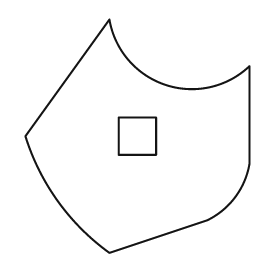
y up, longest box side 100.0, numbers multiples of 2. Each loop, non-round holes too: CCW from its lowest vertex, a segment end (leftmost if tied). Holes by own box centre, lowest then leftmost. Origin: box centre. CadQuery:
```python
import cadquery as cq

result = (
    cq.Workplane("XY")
    .moveTo(-12.0, -50.0)
    .lineTo(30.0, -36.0)
    .threePointArc((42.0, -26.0), (48.0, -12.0))
    .lineTo(48.0, 30.0)
    .threePointArc((12.0, 22.0), (-12.0, 50.0))
    .lineTo(-48.0, 0.0)
    .threePointArc((-34.0, -28.0), (-12.0, -50.0))
    .close()
    .moveTo(-8.0, -8.0)
    .lineTo(8.0, -8.0)
    .lineTo(8.0, 8.0)
    .lineTo(-8.0, 8.0)
    .close()
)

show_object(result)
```